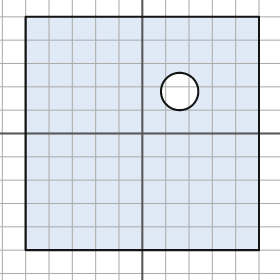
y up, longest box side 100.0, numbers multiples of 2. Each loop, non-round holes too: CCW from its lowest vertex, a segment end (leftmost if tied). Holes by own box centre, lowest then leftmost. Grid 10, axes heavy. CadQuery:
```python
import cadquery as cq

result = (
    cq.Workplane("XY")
    .moveTo(-50.0, -50.0)
    .lineTo(50.0, -50.0)
    .lineTo(50.0, 50.0)
    .lineTo(-50.0, 50.0)
    .close()
    .moveTo(16.0, 18.0)
    .circle(8.0)
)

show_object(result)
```